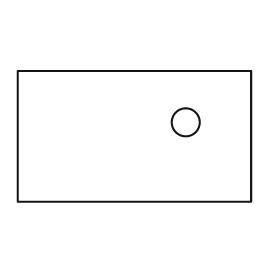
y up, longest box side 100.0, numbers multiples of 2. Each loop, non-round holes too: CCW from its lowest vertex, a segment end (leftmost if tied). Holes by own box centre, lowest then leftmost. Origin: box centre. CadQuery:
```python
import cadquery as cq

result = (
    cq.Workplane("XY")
    .moveTo(-50.0, -28.0)
    .lineTo(50.0, -28.0)
    .lineTo(50.0, 28.0)
    .lineTo(-50.0, 28.0)
    .close()
    .moveTo(22.0, 6.0)
    .circle(6.0)
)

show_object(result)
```